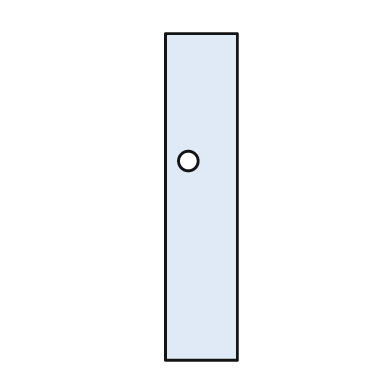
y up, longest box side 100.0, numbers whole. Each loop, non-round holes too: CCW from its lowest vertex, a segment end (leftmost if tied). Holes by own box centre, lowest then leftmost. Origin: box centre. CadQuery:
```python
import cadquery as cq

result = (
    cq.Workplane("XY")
    .moveTo(-11.0, -50.0)
    .lineTo(11.0, -50.0)
    .lineTo(11.0, 50.0)
    .lineTo(-11.0, 50.0)
    .close()
    .moveTo(-4.0, 11.0)
    .circle(3.0)
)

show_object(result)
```